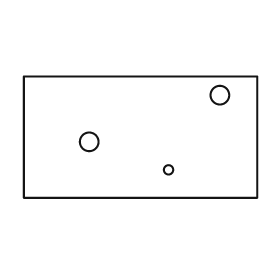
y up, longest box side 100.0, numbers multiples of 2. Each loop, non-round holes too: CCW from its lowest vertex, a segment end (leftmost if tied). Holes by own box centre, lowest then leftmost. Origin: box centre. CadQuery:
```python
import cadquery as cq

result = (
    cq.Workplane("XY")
    .moveTo(-50.0, -26.0)
    .lineTo(50.0, -26.0)
    .lineTo(50.0, 26.0)
    .lineTo(-50.0, 26.0)
    .close()
    .moveTo(12.0, -14.0)
    .circle(2.0)
    .moveTo(-22.0, -2.0)
    .circle(4.0)
    .moveTo(34.0, 18.0)
    .circle(4.0)
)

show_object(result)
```